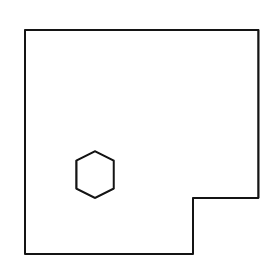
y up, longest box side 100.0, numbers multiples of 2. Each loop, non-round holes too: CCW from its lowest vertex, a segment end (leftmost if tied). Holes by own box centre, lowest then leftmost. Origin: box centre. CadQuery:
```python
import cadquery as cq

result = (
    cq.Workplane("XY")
    .moveTo(-50.0, -48.0)
    .lineTo(22.0, -48.0)
    .lineTo(22.0, -24.0)
    .lineTo(50.0, -24.0)
    .lineTo(50.0, 48.0)
    .lineTo(-50.0, 48.0)
    .close()
    .moveTo(-20.0, -24.0)
    .lineTo(-12.0, -20.0)
    .lineTo(-12.0, -8.0)
    .lineTo(-20.0, -4.0)
    .lineTo(-28.0, -8.0)
    .lineTo(-28.0, -20.0)
    .close()
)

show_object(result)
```